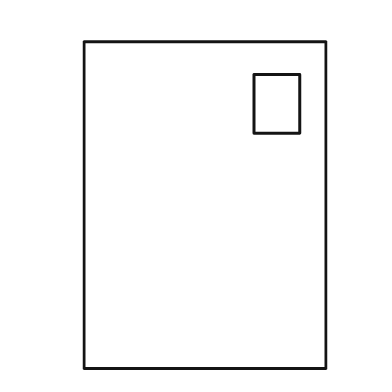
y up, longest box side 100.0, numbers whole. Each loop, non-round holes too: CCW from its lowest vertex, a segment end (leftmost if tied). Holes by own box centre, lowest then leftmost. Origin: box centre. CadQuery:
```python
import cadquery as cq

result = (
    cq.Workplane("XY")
    .moveTo(-37.0, -50.0)
    .lineTo(37.0, -50.0)
    .lineTo(37.0, 50.0)
    .lineTo(-37.0, 50.0)
    .close()
    .moveTo(15.0, 22.0)
    .lineTo(29.0, 22.0)
    .lineTo(29.0, 40.0)
    .lineTo(15.0, 40.0)
    .close()
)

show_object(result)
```